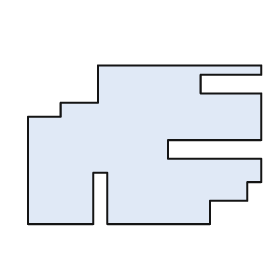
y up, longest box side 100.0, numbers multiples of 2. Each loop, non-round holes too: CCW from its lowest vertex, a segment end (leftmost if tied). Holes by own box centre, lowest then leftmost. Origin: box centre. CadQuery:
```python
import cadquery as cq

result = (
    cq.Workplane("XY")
    .moveTo(-50.0, -34.0)
    .lineTo(-22.0, -34.0)
    .lineTo(-22.0, -12.0)
    .lineTo(-16.0, -12.0)
    .lineTo(-16.0, -34.0)
    .lineTo(28.0, -34.0)
    .lineTo(28.0, -24.0)
    .lineTo(44.0, -24.0)
    .lineTo(44.0, -16.0)
    .lineTo(50.0, -16.0)
    .lineTo(50.0, -6.0)
    .lineTo(10.0, -6.0)
    .lineTo(10.0, 2.0)
    .lineTo(50.0, 2.0)
    .lineTo(50.0, 22.0)
    .lineTo(24.0, 22.0)
    .lineTo(24.0, 30.0)
    .lineTo(50.0, 30.0)
    .lineTo(50.0, 34.0)
    .lineTo(-20.0, 34.0)
    .lineTo(-20.0, 18.0)
    .lineTo(-36.0, 18.0)
    .lineTo(-36.0, 12.0)
    .lineTo(-50.0, 12.0)
    .close()
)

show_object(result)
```